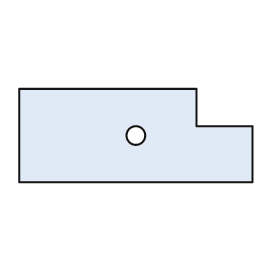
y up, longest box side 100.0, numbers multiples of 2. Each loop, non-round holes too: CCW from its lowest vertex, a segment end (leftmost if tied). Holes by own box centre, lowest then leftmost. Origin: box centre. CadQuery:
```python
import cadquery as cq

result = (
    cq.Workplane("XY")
    .moveTo(-50.0, -20.0)
    .lineTo(50.0, -20.0)
    .lineTo(50.0, 4.0)
    .lineTo(26.0, 4.0)
    .lineTo(26.0, 20.0)
    .lineTo(-50.0, 20.0)
    .close()
    .moveTo(0.0, 0.0)
    .circle(4.0)
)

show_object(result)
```